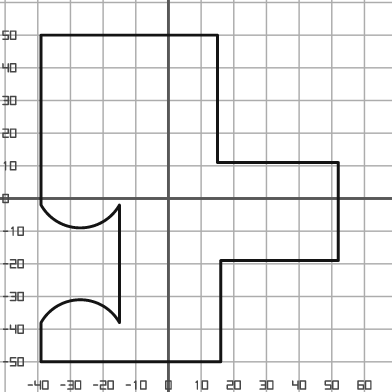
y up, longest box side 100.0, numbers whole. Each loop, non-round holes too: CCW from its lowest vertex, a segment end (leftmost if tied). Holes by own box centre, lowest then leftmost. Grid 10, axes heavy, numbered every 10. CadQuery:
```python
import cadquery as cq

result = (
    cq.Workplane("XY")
    .moveTo(-39.0, -50.0)
    .lineTo(16.0, -50.0)
    .lineTo(16.0, -19.0)
    .lineTo(52.0, -19.0)
    .lineTo(52.0, 11.0)
    .lineTo(15.0, 11.0)
    .lineTo(15.0, 50.0)
    .lineTo(-39.0, 50.0)
    .lineTo(-39.0, -2.0)
    .threePointArc((-27.0, -9.0), (-15.0, -2.0))
    .lineTo(-15.0, -38.0)
    .threePointArc((-27.0, -31.0), (-39.0, -38.0))
    .close()
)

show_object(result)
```